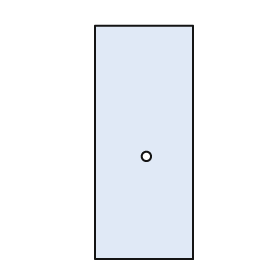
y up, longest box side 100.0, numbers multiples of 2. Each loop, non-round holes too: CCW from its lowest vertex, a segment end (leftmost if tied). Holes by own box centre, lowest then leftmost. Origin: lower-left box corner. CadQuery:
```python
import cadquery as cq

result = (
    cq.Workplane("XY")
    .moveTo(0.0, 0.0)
    .lineTo(42.0, 0.0)
    .lineTo(42.0, 100.0)
    .lineTo(0.0, 100.0)
    .close()
    .moveTo(22.0, 44.0)
    .circle(2.0)
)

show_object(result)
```